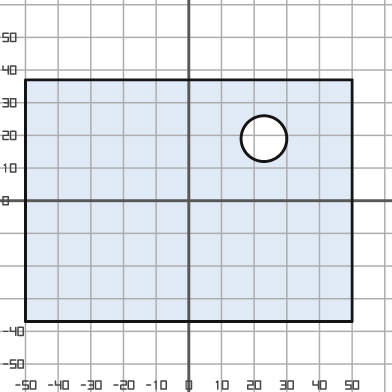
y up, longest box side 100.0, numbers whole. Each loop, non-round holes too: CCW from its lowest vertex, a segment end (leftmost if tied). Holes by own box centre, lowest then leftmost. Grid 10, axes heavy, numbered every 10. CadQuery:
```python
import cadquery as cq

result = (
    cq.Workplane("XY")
    .moveTo(-50.0, -37.0)
    .lineTo(50.0, -37.0)
    .lineTo(50.0, 37.0)
    .lineTo(-50.0, 37.0)
    .close()
    .moveTo(23.0, 19.0)
    .circle(7.0)
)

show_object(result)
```